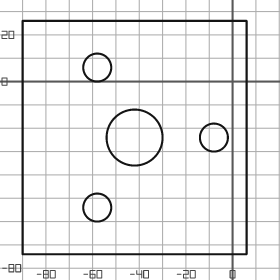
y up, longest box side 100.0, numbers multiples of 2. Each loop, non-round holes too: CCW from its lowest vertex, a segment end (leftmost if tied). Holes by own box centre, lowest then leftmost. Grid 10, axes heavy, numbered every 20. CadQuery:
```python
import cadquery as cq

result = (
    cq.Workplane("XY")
    .moveTo(-90.0, -74.0)
    .lineTo(6.0, -74.0)
    .lineTo(6.0, 26.0)
    .lineTo(-90.0, 26.0)
    .close()
    .moveTo(-58.0, -54.0)
    .circle(6.0)
    .moveTo(-42.0, -24.0)
    .circle(12.0)
    .moveTo(-8.0, -24.0)
    .circle(6.0)
    .moveTo(-58.0, 6.0)
    .circle(6.0)
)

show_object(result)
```